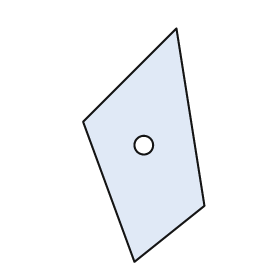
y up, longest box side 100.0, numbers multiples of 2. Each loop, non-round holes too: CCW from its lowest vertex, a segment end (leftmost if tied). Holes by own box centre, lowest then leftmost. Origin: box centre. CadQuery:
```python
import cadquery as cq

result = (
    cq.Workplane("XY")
    .moveTo(-4.0, -50.0)
    .lineTo(26.0, -26.0)
    .lineTo(14.0, 50.0)
    .lineTo(-26.0, 10.0)
    .close()
    .moveTo(0.0, 0.0)
    .circle(4.0)
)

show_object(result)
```